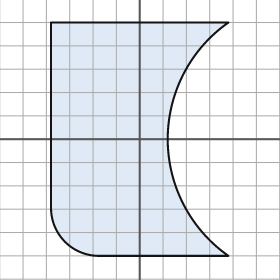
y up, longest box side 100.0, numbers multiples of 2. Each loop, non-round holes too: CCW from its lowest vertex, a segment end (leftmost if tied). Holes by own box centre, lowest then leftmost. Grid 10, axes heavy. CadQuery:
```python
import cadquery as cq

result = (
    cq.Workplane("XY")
    .moveTo(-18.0, -50.0)
    .lineTo(38.0, -50.0)
    .threePointArc((12.0, 0.0), (38.0, 50.0))
    .lineTo(-38.0, 50.0)
    .lineTo(-38.0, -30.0)
    .threePointArc((-32.0, -44.0), (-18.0, -50.0))
    .close()
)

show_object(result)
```